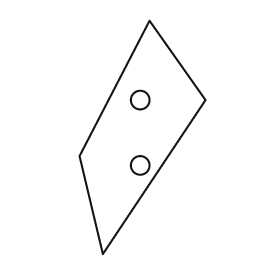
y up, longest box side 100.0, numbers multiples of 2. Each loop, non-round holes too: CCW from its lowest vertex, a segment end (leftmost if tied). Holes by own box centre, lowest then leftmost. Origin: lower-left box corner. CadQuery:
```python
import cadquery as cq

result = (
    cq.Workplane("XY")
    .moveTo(10.0, 0.0)
    .lineTo(54.0, 66.0)
    .lineTo(30.0, 100.0)
    .lineTo(0.0, 42.0)
    .close()
    .moveTo(26.0, 38.0)
    .circle(4.0)
    .moveTo(26.0, 66.0)
    .circle(4.0)
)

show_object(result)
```